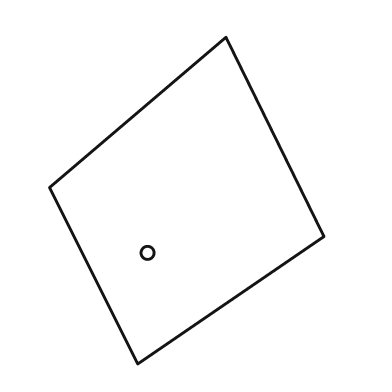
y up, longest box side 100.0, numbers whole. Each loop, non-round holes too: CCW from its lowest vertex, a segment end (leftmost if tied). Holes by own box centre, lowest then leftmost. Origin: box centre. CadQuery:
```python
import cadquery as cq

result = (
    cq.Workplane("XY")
    .moveTo(-15.0, -50.0)
    .lineTo(42.0, -11.0)
    .lineTo(12.0, 50.0)
    .lineTo(-42.0, 4.0)
    .close()
    .moveTo(-12.0, -16.0)
    .circle(2.0)
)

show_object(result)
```